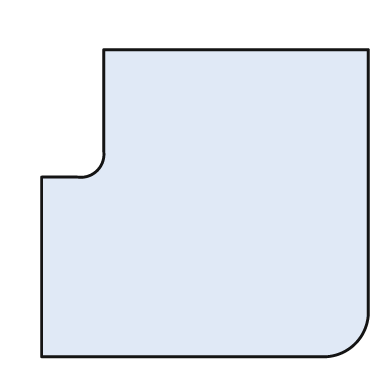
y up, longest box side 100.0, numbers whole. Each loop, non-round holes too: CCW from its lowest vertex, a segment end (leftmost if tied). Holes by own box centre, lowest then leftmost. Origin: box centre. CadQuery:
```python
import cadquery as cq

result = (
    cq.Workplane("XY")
    .moveTo(-50.0, -47.0)
    .lineTo(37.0, -47.0)
    .threePointArc((46.0, -43.0), (50.0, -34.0))
    .lineTo(50.0, 47.0)
    .lineTo(-31.0, 47.0)
    .lineTo(-31.0, 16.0)
    .threePointArc((-33.0, 10.0), (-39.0, 8.0))
    .lineTo(-50.0, 8.0)
    .close()
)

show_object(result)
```